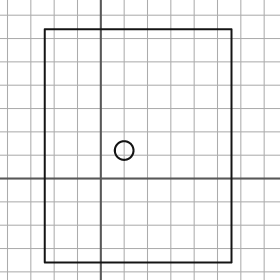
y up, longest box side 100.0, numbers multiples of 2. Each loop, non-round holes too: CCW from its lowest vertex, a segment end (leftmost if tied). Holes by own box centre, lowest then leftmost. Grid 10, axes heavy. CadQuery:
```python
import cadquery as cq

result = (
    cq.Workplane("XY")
    .moveTo(-24.0, -36.0)
    .lineTo(56.0, -36.0)
    .lineTo(56.0, 64.0)
    .lineTo(-24.0, 64.0)
    .close()
    .moveTo(10.0, 12.0)
    .circle(4.0)
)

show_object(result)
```